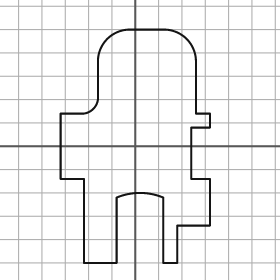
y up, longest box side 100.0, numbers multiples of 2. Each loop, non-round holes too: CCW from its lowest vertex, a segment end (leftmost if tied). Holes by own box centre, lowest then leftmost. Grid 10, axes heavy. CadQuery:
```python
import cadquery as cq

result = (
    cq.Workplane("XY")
    .moveTo(-22.0, -50.0)
    .lineTo(-8.0, -50.0)
    .lineTo(-8.0, -22.0)
    .threePointArc((2.0, -20.0), (12.0, -22.0))
    .lineTo(12.0, -50.0)
    .lineTo(18.0, -50.0)
    .lineTo(18.0, -34.0)
    .lineTo(32.0, -34.0)
    .lineTo(32.0, -14.0)
    .lineTo(24.0, -14.0)
    .lineTo(24.0, 8.0)
    .lineTo(32.0, 8.0)
    .lineTo(32.0, 14.0)
    .lineTo(26.0, 14.0)
    .lineTo(26.0, 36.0)
    .threePointArc((22.0, 46.0), (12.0, 50.0))
    .lineTo(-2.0, 50.0)
    .threePointArc((-12.0, 46.0), (-16.0, 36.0))
    .lineTo(-16.0, 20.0)
    .threePointArc((-18.0, 16.0), (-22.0, 14.0))
    .lineTo(-32.0, 14.0)
    .lineTo(-32.0, -14.0)
    .lineTo(-22.0, -14.0)
    .close()
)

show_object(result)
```